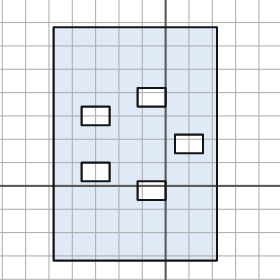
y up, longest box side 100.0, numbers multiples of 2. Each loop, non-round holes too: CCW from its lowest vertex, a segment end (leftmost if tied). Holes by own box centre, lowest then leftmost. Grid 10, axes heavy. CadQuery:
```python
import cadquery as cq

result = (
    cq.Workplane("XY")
    .moveTo(-48.0, -32.0)
    .lineTo(22.0, -32.0)
    .lineTo(22.0, 68.0)
    .lineTo(-48.0, 68.0)
    .close()
    .moveTo(-12.0, -6.0)
    .lineTo(0.0, -6.0)
    .lineTo(0.0, 2.0)
    .lineTo(-12.0, 2.0)
    .close()
    .moveTo(-36.0, 2.0)
    .lineTo(-24.0, 2.0)
    .lineTo(-24.0, 10.0)
    .lineTo(-36.0, 10.0)
    .close()
    .moveTo(4.0, 14.0)
    .lineTo(16.0, 14.0)
    .lineTo(16.0, 22.0)
    .lineTo(4.0, 22.0)
    .close()
    .moveTo(-36.0, 26.0)
    .lineTo(-24.0, 26.0)
    .lineTo(-24.0, 34.0)
    .lineTo(-36.0, 34.0)
    .close()
    .moveTo(-12.0, 34.0)
    .lineTo(0.0, 34.0)
    .lineTo(0.0, 42.0)
    .lineTo(-12.0, 42.0)
    .close()
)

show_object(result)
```